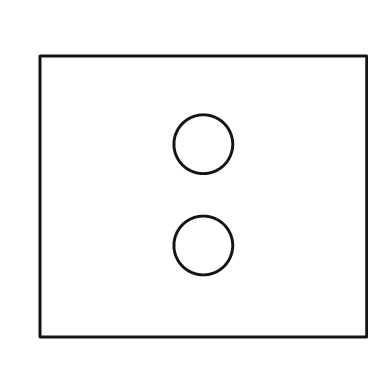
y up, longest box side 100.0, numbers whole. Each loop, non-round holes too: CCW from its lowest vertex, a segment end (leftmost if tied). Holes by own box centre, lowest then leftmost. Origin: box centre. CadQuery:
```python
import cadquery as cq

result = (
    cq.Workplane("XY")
    .moveTo(-50.0, -43.0)
    .lineTo(50.0, -43.0)
    .lineTo(50.0, 43.0)
    .lineTo(-50.0, 43.0)
    .close()
    .moveTo(0.0, -15.0)
    .circle(9.0)
    .moveTo(0.0, 16.0)
    .circle(9.0)
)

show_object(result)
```